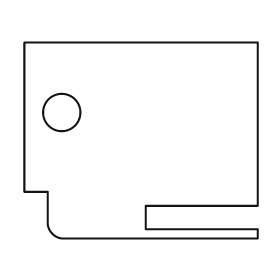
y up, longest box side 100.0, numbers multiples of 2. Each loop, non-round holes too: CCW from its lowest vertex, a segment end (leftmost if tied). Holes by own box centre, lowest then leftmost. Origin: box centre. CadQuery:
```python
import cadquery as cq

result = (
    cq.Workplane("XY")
    .moveTo(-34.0, -42.0)
    .lineTo(50.0, -42.0)
    .lineTo(50.0, -38.0)
    .lineTo(2.0, -38.0)
    .lineTo(2.0, -28.0)
    .lineTo(50.0, -28.0)
    .lineTo(50.0, 42.0)
    .lineTo(-50.0, 42.0)
    .lineTo(-50.0, -22.0)
    .lineTo(-40.0, -22.0)
    .lineTo(-40.0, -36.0)
    .threePointArc((-38.0, -40.0), (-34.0, -42.0))
    .close()
    .moveTo(-34.0, 12.0)
    .circle(8.0)
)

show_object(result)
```